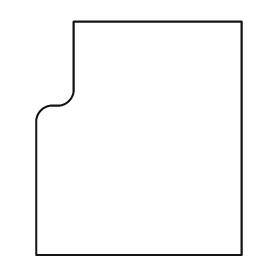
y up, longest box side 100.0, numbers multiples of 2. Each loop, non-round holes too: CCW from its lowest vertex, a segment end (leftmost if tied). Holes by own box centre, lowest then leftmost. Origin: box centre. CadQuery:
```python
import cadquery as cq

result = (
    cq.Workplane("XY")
    .moveTo(-44.0, -50.0)
    .lineTo(44.0, -50.0)
    .lineTo(44.0, 50.0)
    .lineTo(-28.0, 50.0)
    .lineTo(-28.0, 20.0)
    .threePointArc((-30.0, 16.0), (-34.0, 14.0))
    .lineTo(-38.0, 14.0)
    .threePointArc((-42.0, 12.0), (-44.0, 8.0))
    .close()
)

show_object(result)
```